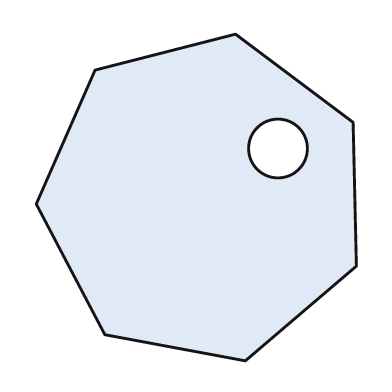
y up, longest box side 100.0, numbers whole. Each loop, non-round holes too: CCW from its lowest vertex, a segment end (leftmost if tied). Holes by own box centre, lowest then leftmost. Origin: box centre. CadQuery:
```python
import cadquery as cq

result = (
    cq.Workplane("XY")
    .moveTo(15.0, -50.0)
    .lineTo(49.0, -21.0)
    .lineTo(48.0, 23.0)
    .lineTo(12.0, 50.0)
    .lineTo(-31.0, 39.0)
    .lineTo(-49.0, -2.0)
    .lineTo(-28.0, -42.0)
    .close()
    .moveTo(25.0, 15.0)
    .circle(9.0)
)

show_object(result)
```